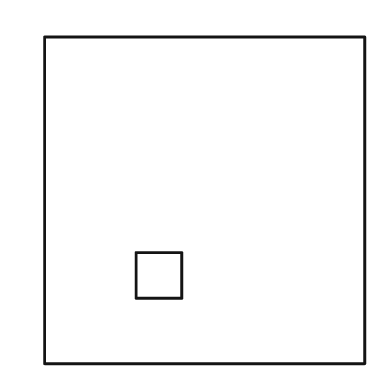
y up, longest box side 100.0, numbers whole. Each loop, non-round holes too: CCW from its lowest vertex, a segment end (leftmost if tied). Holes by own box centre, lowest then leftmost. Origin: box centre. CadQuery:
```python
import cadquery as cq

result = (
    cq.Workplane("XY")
    .moveTo(-49.0, -50.0)
    .lineTo(49.0, -50.0)
    .lineTo(49.0, 50.0)
    .lineTo(-49.0, 50.0)
    .close()
    .moveTo(-21.0, -30.0)
    .lineTo(-7.0, -30.0)
    .lineTo(-7.0, -16.0)
    .lineTo(-21.0, -16.0)
    .close()
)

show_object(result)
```